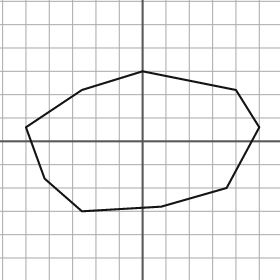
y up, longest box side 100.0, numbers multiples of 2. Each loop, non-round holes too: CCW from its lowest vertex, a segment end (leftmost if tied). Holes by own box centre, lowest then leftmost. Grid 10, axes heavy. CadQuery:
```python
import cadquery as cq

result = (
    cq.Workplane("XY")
    .moveTo(-26.0, -30.0)
    .lineTo(8.0, -28.0)
    .lineTo(36.0, -20.0)
    .lineTo(50.0, 6.0)
    .lineTo(40.0, 22.0)
    .lineTo(0.0, 30.0)
    .lineTo(-26.0, 22.0)
    .lineTo(-50.0, 6.0)
    .lineTo(-42.0, -16.0)
    .close()
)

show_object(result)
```